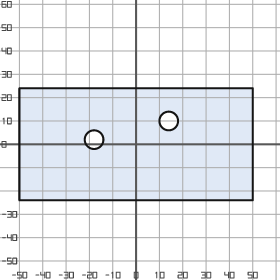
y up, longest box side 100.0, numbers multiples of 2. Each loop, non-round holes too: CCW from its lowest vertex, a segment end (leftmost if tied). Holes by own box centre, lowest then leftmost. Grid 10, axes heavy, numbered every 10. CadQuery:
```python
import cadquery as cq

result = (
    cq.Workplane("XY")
    .moveTo(-50.0, -24.0)
    .lineTo(50.0, -24.0)
    .lineTo(50.0, 24.0)
    .lineTo(-50.0, 24.0)
    .close()
    .moveTo(-18.0, 2.0)
    .circle(4.0)
    .moveTo(14.0, 10.0)
    .circle(4.0)
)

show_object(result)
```